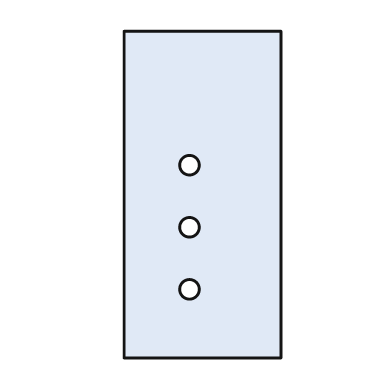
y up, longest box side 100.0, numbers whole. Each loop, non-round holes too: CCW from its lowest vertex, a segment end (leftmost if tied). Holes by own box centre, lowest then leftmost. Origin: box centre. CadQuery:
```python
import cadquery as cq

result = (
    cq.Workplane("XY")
    .moveTo(-24.0, -50.0)
    .lineTo(24.0, -50.0)
    .lineTo(24.0, 50.0)
    .lineTo(-24.0, 50.0)
    .close()
    .moveTo(-4.0, -29.0)
    .circle(3.0)
    .moveTo(-4.0, -10.0)
    .circle(3.0)
    .moveTo(-4.0, 9.0)
    .circle(3.0)
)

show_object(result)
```